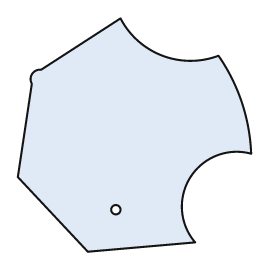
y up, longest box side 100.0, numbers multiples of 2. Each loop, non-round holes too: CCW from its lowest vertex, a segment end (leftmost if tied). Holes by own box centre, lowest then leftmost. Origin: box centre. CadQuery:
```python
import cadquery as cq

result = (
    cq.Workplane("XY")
    .moveTo(-20.0, -50.0)
    .lineTo(26.0, -46.0)
    .threePointArc((24.0, -18.0), (50.0, -8.0))
    .threePointArc((46.0, 14.0), (36.0, 34.0))
    .threePointArc((12.0, 34.0), (-6.0, 50.0))
    .lineTo(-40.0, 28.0)
    .threePointArc((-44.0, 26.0), (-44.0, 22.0))
    .lineTo(-50.0, -18.0)
    .close()
    .moveTo(-8.0, -32.0)
    .circle(2.0)
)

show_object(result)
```